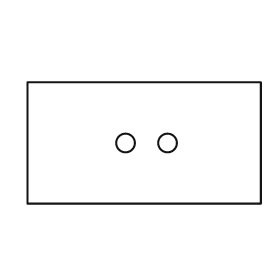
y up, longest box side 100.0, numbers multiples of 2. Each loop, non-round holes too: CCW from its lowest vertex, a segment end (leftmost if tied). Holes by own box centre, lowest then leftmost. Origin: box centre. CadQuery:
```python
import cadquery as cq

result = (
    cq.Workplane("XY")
    .moveTo(-50.0, -26.0)
    .lineTo(50.0, -26.0)
    .lineTo(50.0, 26.0)
    .lineTo(-50.0, 26.0)
    .close()
    .moveTo(-8.0, 0.0)
    .circle(4.0)
    .moveTo(10.0, 0.0)
    .circle(4.0)
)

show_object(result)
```